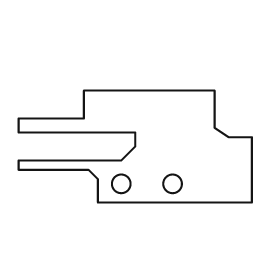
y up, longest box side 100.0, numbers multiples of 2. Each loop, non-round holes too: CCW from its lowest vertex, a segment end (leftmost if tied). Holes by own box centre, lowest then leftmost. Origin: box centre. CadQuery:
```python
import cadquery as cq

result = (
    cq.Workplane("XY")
    .moveTo(-16.0, -24.0)
    .lineTo(50.0, -24.0)
    .lineTo(50.0, 4.0)
    .lineTo(40.0, 4.0)
    .lineTo(34.0, 8.0)
    .lineTo(34.0, 24.0)
    .lineTo(-22.0, 24.0)
    .lineTo(-22.0, 12.0)
    .lineTo(-50.0, 12.0)
    .lineTo(-50.0, 6.0)
    .lineTo(0.0, 6.0)
    .lineTo(0.0, 0.0)
    .lineTo(-6.0, -6.0)
    .lineTo(-50.0, -6.0)
    .lineTo(-50.0, -10.0)
    .lineTo(-20.0, -10.0)
    .lineTo(-16.0, -14.0)
    .close()
    .moveTo(-6.0, -16.0)
    .circle(4.0)
    .moveTo(16.0, -16.0)
    .circle(4.0)
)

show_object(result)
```